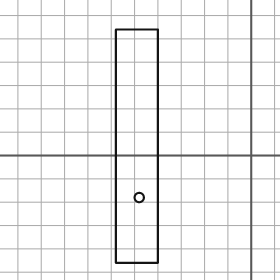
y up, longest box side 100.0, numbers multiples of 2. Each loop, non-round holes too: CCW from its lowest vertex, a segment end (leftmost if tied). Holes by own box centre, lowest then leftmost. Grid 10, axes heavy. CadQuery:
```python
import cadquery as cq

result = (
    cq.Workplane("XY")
    .moveTo(-58.0, -46.0)
    .lineTo(-40.0, -46.0)
    .lineTo(-40.0, 54.0)
    .lineTo(-58.0, 54.0)
    .close()
    .moveTo(-48.0, -18.0)
    .circle(2.0)
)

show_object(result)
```